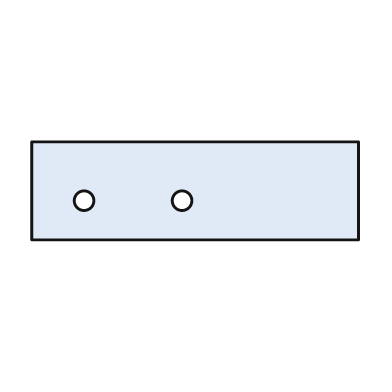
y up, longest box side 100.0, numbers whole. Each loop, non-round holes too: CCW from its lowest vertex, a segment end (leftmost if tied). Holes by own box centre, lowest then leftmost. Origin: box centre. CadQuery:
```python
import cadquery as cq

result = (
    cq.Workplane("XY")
    .moveTo(-50.0, -15.0)
    .lineTo(50.0, -15.0)
    .lineTo(50.0, 15.0)
    .lineTo(-50.0, 15.0)
    .close()
    .moveTo(-34.0, -3.0)
    .circle(3.0)
    .moveTo(-4.0, -3.0)
    .circle(3.0)
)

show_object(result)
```